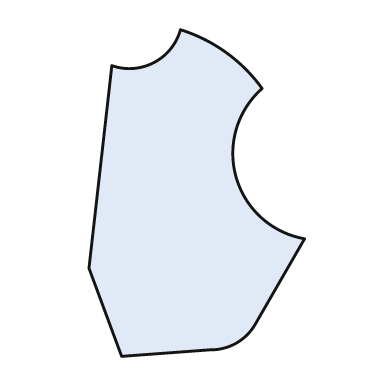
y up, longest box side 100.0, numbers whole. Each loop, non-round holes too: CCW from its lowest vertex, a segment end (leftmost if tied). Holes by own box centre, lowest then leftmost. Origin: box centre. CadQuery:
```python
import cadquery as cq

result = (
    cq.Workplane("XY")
    .moveTo(-23.0, -50.0)
    .lineTo(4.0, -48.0)
    .threePointArc((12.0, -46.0), (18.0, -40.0))
    .lineTo(33.0, -14.0)
    .threePointArc((12.0, 5.0), (20.0, 32.0))
    .threePointArc((9.0, 43.0), (-5.0, 50.0))
    .threePointArc((-13.0, 40.0), (-26.0, 39.0))
    .lineTo(-33.0, -23.0)
    .close()
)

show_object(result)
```